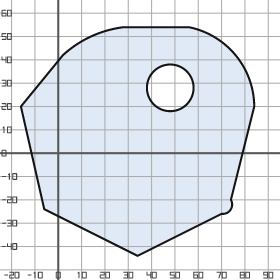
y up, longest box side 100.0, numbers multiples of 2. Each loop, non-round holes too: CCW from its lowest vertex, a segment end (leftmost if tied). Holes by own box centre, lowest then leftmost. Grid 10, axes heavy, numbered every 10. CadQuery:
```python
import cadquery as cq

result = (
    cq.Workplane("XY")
    .moveTo(34.0, -44.0)
    .lineTo(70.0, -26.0)
    .threePointArc((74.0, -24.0), (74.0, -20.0))
    .lineTo(84.0, 20.0)
    .threePointArc((76.0, 42.0), (56.0, 54.0))
    .lineTo(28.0, 54.0)
    .threePointArc((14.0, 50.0), (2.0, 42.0))
    .lineTo(-16.0, 20.0)
    .lineTo(-6.0, -24.0)
    .close()
    .moveTo(48.0, 28.0)
    .circle(10.0)
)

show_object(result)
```